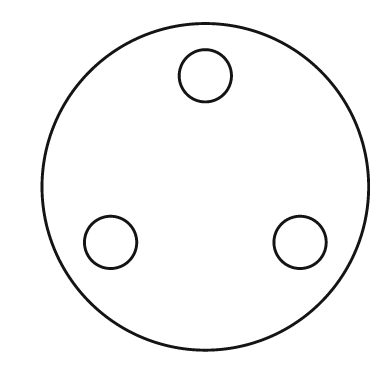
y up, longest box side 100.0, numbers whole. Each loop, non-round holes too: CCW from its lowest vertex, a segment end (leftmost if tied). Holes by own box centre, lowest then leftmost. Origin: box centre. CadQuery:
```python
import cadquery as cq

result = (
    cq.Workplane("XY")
    .moveTo(0.0, 0.0)
    .circle(50.0)
    .moveTo(-29.0, -17.0)
    .circle(8.0)
    .moveTo(29.0, -17.0)
    .circle(8.0)
    .moveTo(0.0, 34.0)
    .circle(8.0)
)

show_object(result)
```